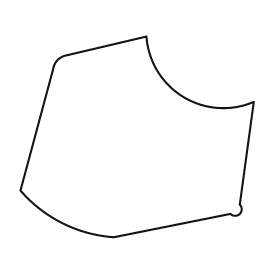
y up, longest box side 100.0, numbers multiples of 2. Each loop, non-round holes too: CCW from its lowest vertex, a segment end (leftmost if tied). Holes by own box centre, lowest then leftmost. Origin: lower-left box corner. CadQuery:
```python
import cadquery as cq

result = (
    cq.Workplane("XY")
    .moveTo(40.0, 0.0)
    .lineTo(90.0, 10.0)
    .threePointArc((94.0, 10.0), (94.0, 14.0))
    .lineTo(100.0, 58.0)
    .threePointArc((70.0, 60.0), (54.0, 86.0))
    .lineTo(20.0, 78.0)
    .threePointArc((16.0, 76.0), (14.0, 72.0))
    .lineTo(0.0, 20.0)
    .threePointArc((18.0, 6.0), (40.0, 0.0))
    .close()
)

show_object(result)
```